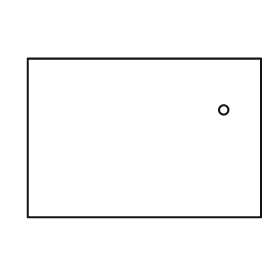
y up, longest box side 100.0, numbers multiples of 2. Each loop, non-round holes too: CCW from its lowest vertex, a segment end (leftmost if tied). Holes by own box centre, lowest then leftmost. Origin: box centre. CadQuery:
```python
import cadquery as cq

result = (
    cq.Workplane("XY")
    .moveTo(-50.0, -34.0)
    .lineTo(50.0, -34.0)
    .lineTo(50.0, 34.0)
    .lineTo(-50.0, 34.0)
    .close()
    .moveTo(34.0, 12.0)
    .circle(2.0)
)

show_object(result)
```